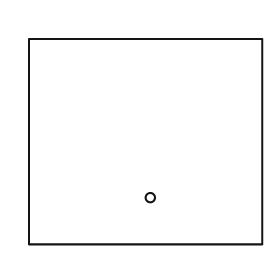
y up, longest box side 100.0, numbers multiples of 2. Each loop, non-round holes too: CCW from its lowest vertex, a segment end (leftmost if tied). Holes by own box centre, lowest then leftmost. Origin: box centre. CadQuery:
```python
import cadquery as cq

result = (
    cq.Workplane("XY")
    .moveTo(-50.0, -44.0)
    .lineTo(50.0, -44.0)
    .lineTo(50.0, 44.0)
    .lineTo(-50.0, 44.0)
    .close()
    .moveTo(2.0, -24.0)
    .circle(2.0)
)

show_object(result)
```